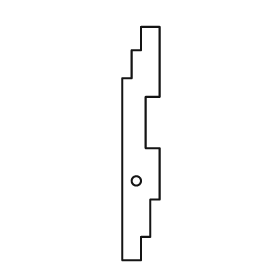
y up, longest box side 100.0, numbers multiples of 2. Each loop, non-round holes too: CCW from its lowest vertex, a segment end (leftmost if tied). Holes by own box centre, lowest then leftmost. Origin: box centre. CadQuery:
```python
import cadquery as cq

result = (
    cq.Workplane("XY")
    .moveTo(-8.0, -50.0)
    .lineTo(0.0, -50.0)
    .lineTo(0.0, -40.0)
    .lineTo(4.0, -40.0)
    .lineTo(4.0, -24.0)
    .lineTo(8.0, -24.0)
    .lineTo(8.0, -2.0)
    .lineTo(2.0, -2.0)
    .lineTo(2.0, 20.0)
    .lineTo(8.0, 20.0)
    .lineTo(8.0, 50.0)
    .lineTo(0.0, 50.0)
    .lineTo(0.0, 40.0)
    .lineTo(-4.0, 40.0)
    .lineTo(-4.0, 28.0)
    .lineTo(-8.0, 28.0)
    .close()
    .moveTo(-2.0, -16.0)
    .circle(2.0)
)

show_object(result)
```